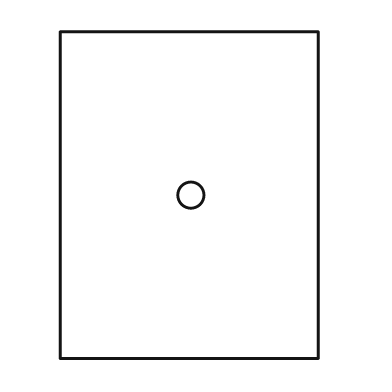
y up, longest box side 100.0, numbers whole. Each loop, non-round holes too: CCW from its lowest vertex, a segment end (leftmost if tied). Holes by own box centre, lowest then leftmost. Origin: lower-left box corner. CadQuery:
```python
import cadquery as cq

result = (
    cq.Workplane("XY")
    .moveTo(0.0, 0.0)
    .lineTo(79.0, 0.0)
    .lineTo(79.0, 100.0)
    .lineTo(0.0, 100.0)
    .close()
    .moveTo(40.0, 50.0)
    .circle(4.0)
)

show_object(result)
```